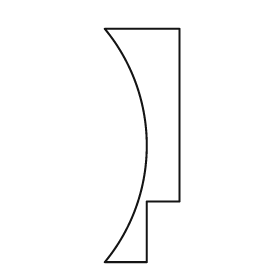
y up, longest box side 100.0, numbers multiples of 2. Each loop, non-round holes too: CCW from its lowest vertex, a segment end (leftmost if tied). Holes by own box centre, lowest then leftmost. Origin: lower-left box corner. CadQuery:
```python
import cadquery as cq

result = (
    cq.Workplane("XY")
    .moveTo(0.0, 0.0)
    .lineTo(18.0, 0.0)
    .lineTo(18.0, 26.0)
    .lineTo(32.0, 26.0)
    .lineTo(32.0, 100.0)
    .lineTo(0.0, 100.0)
    .threePointArc((18.0, 50.0), (0.0, 0.0))
    .close()
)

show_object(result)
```